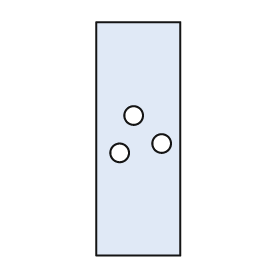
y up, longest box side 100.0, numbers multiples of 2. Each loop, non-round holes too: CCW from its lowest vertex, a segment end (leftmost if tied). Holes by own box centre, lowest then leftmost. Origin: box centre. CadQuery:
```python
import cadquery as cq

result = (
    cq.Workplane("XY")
    .moveTo(-18.0, -50.0)
    .lineTo(18.0, -50.0)
    .lineTo(18.0, 50.0)
    .lineTo(-18.0, 50.0)
    .close()
    .moveTo(-8.0, -6.0)
    .circle(4.0)
    .moveTo(10.0, -2.0)
    .circle(4.0)
    .moveTo(-2.0, 10.0)
    .circle(4.0)
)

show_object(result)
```